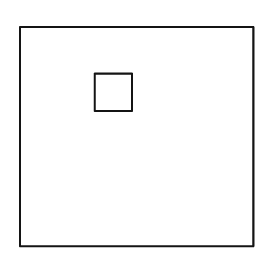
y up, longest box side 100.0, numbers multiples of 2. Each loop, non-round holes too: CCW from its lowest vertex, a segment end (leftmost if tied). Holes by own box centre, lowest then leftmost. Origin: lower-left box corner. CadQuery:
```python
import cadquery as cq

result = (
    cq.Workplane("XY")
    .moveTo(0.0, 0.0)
    .lineTo(100.0, 0.0)
    .lineTo(100.0, 94.0)
    .lineTo(0.0, 94.0)
    .close()
    .moveTo(32.0, 58.0)
    .lineTo(48.0, 58.0)
    .lineTo(48.0, 74.0)
    .lineTo(32.0, 74.0)
    .close()
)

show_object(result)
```